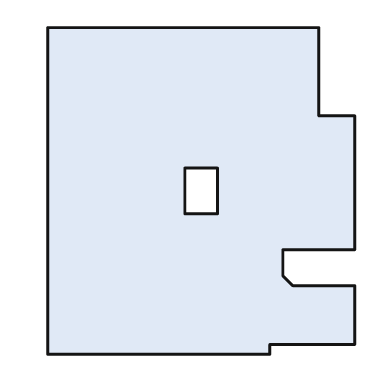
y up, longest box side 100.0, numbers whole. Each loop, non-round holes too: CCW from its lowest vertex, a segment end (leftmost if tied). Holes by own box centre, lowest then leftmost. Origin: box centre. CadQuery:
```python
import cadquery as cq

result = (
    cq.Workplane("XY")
    .moveTo(-47.0, -50.0)
    .lineTo(21.0, -50.0)
    .lineTo(21.0, -47.0)
    .lineTo(47.0, -47.0)
    .lineTo(47.0, -29.0)
    .lineTo(28.0, -29.0)
    .lineTo(25.0, -26.0)
    .lineTo(25.0, -18.0)
    .lineTo(47.0, -18.0)
    .lineTo(47.0, 23.0)
    .lineTo(36.0, 23.0)
    .lineTo(36.0, 50.0)
    .lineTo(-47.0, 50.0)
    .close()
    .moveTo(-5.0, -7.0)
    .lineTo(5.0, -7.0)
    .lineTo(5.0, 7.0)
    .lineTo(-5.0, 7.0)
    .close()
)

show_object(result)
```